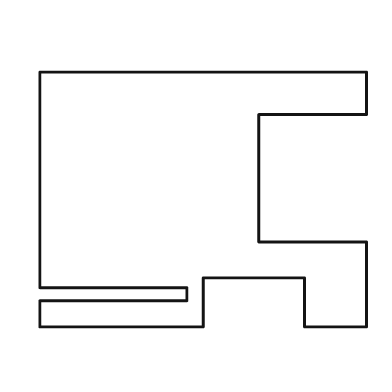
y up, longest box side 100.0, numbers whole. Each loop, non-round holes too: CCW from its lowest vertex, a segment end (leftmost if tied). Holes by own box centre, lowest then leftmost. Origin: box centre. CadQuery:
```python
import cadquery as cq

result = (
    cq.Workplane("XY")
    .moveTo(-50.0, -39.0)
    .lineTo(0.0, -39.0)
    .lineTo(0.0, -24.0)
    .lineTo(31.0, -24.0)
    .lineTo(31.0, -39.0)
    .lineTo(50.0, -39.0)
    .lineTo(50.0, -13.0)
    .lineTo(17.0, -13.0)
    .lineTo(17.0, 26.0)
    .lineTo(50.0, 26.0)
    .lineTo(50.0, 39.0)
    .lineTo(-50.0, 39.0)
    .lineTo(-50.0, -27.0)
    .lineTo(-5.0, -27.0)
    .lineTo(-5.0, -31.0)
    .lineTo(-50.0, -31.0)
    .close()
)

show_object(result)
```